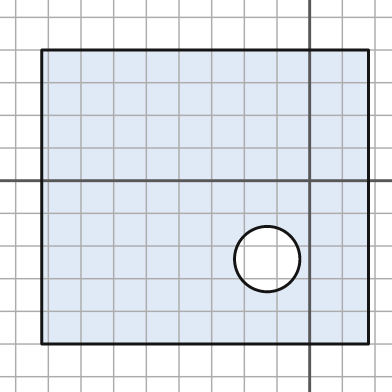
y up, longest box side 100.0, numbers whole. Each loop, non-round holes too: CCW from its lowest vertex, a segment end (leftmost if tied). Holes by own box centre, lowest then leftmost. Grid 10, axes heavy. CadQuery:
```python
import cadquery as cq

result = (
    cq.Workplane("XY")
    .moveTo(-82.0, -50.0)
    .lineTo(18.0, -50.0)
    .lineTo(18.0, 40.0)
    .lineTo(-82.0, 40.0)
    .close()
    .moveTo(-13.0, -24.0)
    .circle(10.0)
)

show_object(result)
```